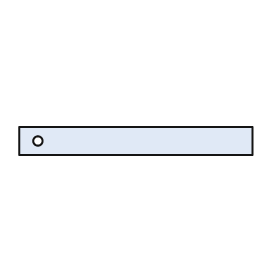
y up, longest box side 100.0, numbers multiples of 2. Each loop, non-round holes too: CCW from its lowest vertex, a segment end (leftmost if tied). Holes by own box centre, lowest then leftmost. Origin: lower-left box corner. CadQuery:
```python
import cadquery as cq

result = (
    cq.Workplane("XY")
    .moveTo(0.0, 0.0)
    .lineTo(100.0, 0.0)
    .lineTo(100.0, 12.0)
    .lineTo(0.0, 12.0)
    .close()
    .moveTo(8.0, 6.0)
    .circle(2.0)
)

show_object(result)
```